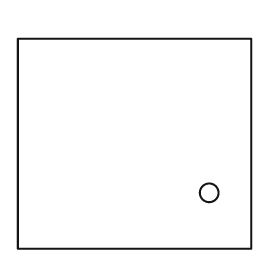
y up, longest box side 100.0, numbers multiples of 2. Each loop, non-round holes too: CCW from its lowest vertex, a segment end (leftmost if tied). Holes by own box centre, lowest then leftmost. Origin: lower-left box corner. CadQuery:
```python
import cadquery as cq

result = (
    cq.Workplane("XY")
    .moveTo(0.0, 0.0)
    .lineTo(100.0, 0.0)
    .lineTo(100.0, 90.0)
    .lineTo(0.0, 90.0)
    .close()
    .moveTo(82.0, 24.0)
    .circle(4.0)
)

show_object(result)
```